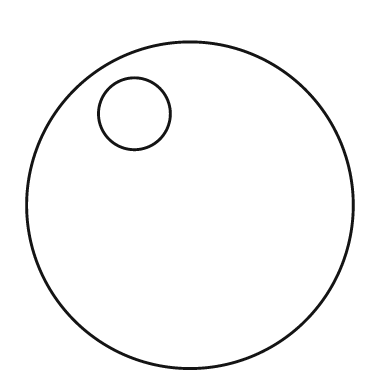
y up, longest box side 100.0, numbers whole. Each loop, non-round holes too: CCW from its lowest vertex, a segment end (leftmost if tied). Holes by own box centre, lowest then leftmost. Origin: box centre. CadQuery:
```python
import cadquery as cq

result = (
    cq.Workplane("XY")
    .moveTo(0.0, 0.0)
    .circle(50.0)
    .moveTo(-17.0, 28.0)
    .circle(11.0)
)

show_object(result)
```